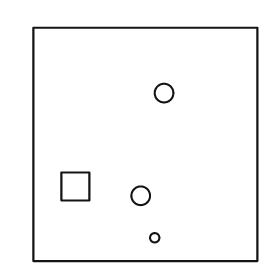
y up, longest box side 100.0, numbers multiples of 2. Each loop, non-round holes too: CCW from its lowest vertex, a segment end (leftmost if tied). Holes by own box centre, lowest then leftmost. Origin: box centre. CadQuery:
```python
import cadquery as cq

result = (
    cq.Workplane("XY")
    .moveTo(-48.0, -50.0)
    .lineTo(48.0, -50.0)
    .lineTo(48.0, 50.0)
    .lineTo(-48.0, 50.0)
    .close()
    .moveTo(4.0, -40.0)
    .circle(2.0)
    .moveTo(-2.0, -22.0)
    .circle(4.0)
    .moveTo(-36.0, -24.0)
    .lineTo(-24.0, -24.0)
    .lineTo(-24.0, -12.0)
    .lineTo(-36.0, -12.0)
    .close()
    .moveTo(8.0, 22.0)
    .circle(4.0)
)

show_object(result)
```